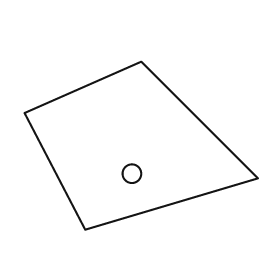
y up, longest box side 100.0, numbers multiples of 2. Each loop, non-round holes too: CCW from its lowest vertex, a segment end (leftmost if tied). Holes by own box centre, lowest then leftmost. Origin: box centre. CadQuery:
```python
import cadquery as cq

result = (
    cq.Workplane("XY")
    .moveTo(-24.0, -36.0)
    .lineTo(50.0, -14.0)
    .lineTo(0.0, 36.0)
    .lineTo(-50.0, 14.0)
    .close()
    .moveTo(-4.0, -12.0)
    .circle(4.0)
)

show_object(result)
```